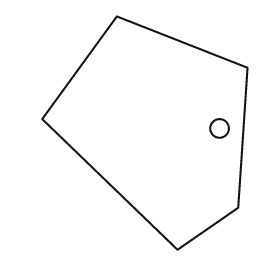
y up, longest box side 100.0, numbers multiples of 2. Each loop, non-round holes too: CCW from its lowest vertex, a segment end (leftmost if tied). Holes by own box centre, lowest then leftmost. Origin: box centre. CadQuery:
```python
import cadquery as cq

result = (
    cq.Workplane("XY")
    .moveTo(14.0, -50.0)
    .lineTo(40.0, -32.0)
    .lineTo(44.0, 28.0)
    .lineTo(-12.0, 50.0)
    .lineTo(-44.0, 6.0)
    .close()
    .moveTo(32.0, 2.0)
    .circle(4.0)
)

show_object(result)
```